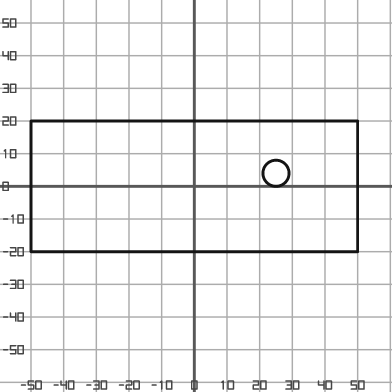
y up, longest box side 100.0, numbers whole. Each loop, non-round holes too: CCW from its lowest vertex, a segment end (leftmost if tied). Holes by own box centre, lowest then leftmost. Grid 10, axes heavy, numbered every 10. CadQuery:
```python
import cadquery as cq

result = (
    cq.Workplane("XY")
    .moveTo(-50.0, -20.0)
    .lineTo(50.0, -20.0)
    .lineTo(50.0, 20.0)
    .lineTo(-50.0, 20.0)
    .close()
    .moveTo(25.0, 4.0)
    .circle(4.0)
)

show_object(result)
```